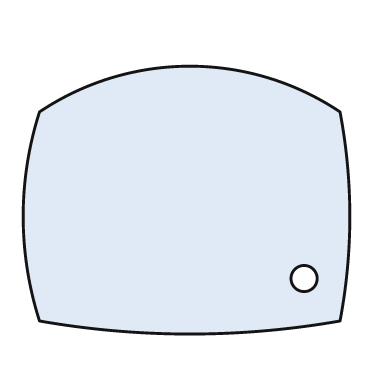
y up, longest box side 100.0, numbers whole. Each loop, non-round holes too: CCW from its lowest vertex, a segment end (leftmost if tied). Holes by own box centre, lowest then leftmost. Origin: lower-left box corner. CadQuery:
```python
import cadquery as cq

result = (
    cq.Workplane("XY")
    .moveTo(5.0, 4.0)
    .threePointArc((51.0, 0.0), (97.0, 4.0))
    .threePointArc((100.0, 36.0), (97.0, 68.0))
    .threePointArc((51.0, 82.0), (5.0, 68.0))
    .threePointArc((0.0, 36.0), (5.0, 4.0))
    .close()
    .moveTo(86.0, 17.0)
    .circle(4.0)
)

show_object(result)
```